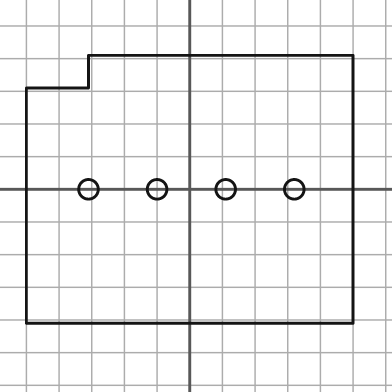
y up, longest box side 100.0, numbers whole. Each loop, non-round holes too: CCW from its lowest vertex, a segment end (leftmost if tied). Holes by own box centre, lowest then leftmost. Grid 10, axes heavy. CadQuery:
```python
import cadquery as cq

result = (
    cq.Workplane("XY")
    .moveTo(-50.0, -41.0)
    .lineTo(50.0, -41.0)
    .lineTo(50.0, 41.0)
    .lineTo(-31.0, 41.0)
    .lineTo(-31.0, 31.0)
    .lineTo(-50.0, 31.0)
    .close()
    .moveTo(-31.0, 0.0)
    .circle(3.0)
    .moveTo(-10.0, 0.0)
    .circle(3.0)
    .moveTo(11.0, 0.0)
    .circle(3.0)
    .moveTo(32.0, 0.0)
    .circle(3.0)
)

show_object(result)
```